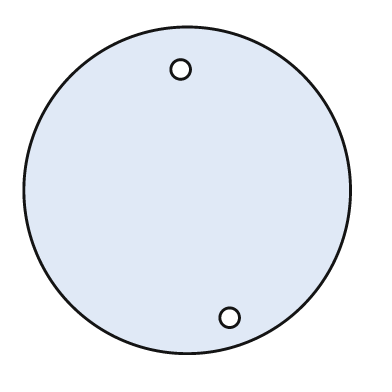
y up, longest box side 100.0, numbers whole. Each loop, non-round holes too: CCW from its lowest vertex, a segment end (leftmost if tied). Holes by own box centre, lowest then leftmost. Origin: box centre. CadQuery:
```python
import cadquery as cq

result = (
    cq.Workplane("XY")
    .moveTo(0.0, 0.0)
    .circle(50.0)
    .moveTo(13.0, -39.0)
    .circle(3.0)
    .moveTo(-2.0, 37.0)
    .circle(3.0)
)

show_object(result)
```